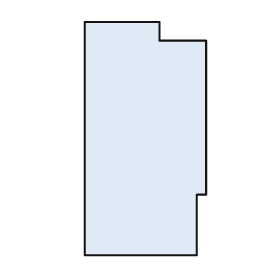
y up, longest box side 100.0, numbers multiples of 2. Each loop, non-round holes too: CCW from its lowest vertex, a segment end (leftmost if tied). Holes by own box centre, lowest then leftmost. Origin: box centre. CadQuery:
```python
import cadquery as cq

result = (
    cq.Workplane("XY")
    .moveTo(-26.0, -50.0)
    .lineTo(22.0, -50.0)
    .lineTo(22.0, -24.0)
    .lineTo(26.0, -24.0)
    .lineTo(26.0, 42.0)
    .lineTo(6.0, 42.0)
    .lineTo(6.0, 50.0)
    .lineTo(-26.0, 50.0)
    .close()
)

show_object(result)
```